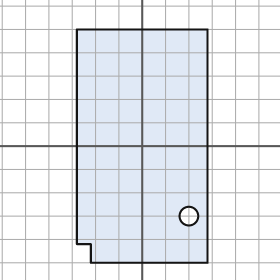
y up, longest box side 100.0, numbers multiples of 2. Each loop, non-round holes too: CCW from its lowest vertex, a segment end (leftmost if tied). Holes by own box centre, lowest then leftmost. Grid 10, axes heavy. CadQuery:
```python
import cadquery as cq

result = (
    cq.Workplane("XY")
    .moveTo(-22.0, -50.0)
    .lineTo(28.0, -50.0)
    .lineTo(28.0, 50.0)
    .lineTo(-28.0, 50.0)
    .lineTo(-28.0, -42.0)
    .lineTo(-22.0, -42.0)
    .close()
    .moveTo(20.0, -30.0)
    .circle(4.0)
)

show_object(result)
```